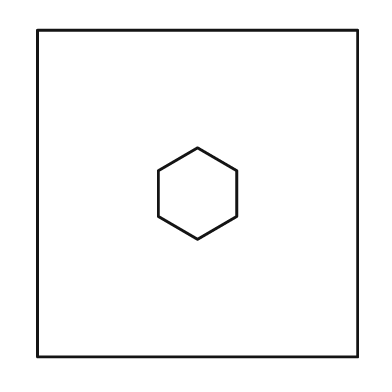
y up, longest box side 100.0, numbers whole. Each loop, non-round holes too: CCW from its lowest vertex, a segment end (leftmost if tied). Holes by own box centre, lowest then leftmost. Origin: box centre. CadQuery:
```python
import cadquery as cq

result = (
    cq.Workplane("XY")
    .moveTo(-49.0, -50.0)
    .lineTo(49.0, -50.0)
    .lineTo(49.0, 50.0)
    .lineTo(-49.0, 50.0)
    .close()
    .moveTo(0.0, -14.0)
    .lineTo(12.0, -7.0)
    .lineTo(12.0, 7.0)
    .lineTo(0.0, 14.0)
    .lineTo(-12.0, 7.0)
    .lineTo(-12.0, -7.0)
    .close()
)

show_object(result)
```